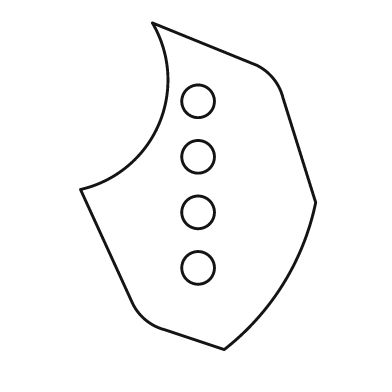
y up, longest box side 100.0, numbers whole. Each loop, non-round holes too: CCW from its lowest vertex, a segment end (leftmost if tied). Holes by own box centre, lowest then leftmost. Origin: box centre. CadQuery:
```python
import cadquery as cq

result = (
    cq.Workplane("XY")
    .moveTo(8.0, -50.0)
    .threePointArc((26.0, -30.0), (36.0, -5.0))
    .lineTo(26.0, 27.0)
    .threePointArc((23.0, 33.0), (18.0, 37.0))
    .lineTo(-14.0, 50.0)
    .threePointArc((-12.0, 19.0), (-36.0, -1.0))
    .lineTo(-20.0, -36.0)
    .threePointArc((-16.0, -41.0), (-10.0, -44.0))
    .close()
    .moveTo(0.0, -25.0)
    .circle(5.0)
    .moveTo(0.0, -8.0)
    .circle(5.0)
    .moveTo(0.0, 9.0)
    .circle(5.0)
    .moveTo(0.0, 26.0)
    .circle(5.0)
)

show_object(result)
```